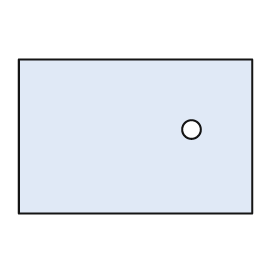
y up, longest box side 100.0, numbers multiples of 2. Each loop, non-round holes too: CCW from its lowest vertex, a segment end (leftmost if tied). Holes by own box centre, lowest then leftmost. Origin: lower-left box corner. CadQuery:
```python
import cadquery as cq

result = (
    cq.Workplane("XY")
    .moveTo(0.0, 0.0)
    .lineTo(100.0, 0.0)
    .lineTo(100.0, 66.0)
    .lineTo(0.0, 66.0)
    .close()
    .moveTo(74.0, 36.0)
    .circle(4.0)
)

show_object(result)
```